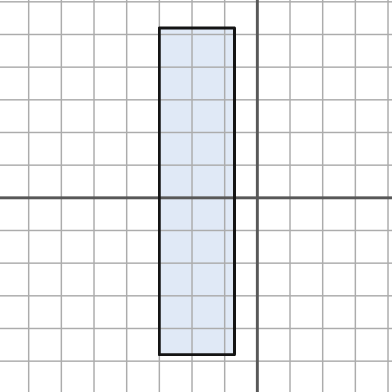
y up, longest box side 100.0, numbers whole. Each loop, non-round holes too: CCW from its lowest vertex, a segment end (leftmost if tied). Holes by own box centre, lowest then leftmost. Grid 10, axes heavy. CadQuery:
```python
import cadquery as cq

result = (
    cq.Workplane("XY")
    .moveTo(-30.0, -48.0)
    .lineTo(-7.0, -48.0)
    .lineTo(-7.0, 52.0)
    .lineTo(-30.0, 52.0)
    .close()
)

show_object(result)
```